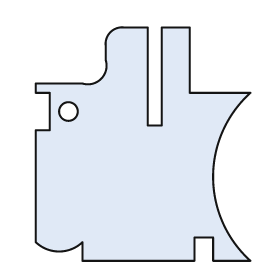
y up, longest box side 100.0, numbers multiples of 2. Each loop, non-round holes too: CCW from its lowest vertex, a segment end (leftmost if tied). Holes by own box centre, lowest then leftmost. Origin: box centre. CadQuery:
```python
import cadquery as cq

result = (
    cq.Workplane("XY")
    .moveTo(-26.0, -50.0)
    .lineTo(22.0, -50.0)
    .lineTo(22.0, -40.0)
    .lineTo(30.0, -40.0)
    .lineTo(30.0, -50.0)
    .lineTo(46.0, -50.0)
    .threePointArc((30.0, -14.0), (46.0, 22.0))
    .lineTo(20.0, 22.0)
    .lineTo(20.0, 50.0)
    .lineTo(8.0, 50.0)
    .lineTo(8.0, 8.0)
    .lineTo(2.0, 8.0)
    .lineTo(2.0, 50.0)
    .lineTo(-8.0, 50.0)
    .threePointArc((-14.0, 48.0), (-16.0, 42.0))
    .lineTo(-16.0, 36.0)
    .threePointArc((-18.0, 28.0), (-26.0, 26.0))
    .lineTo(-46.0, 26.0)
    .lineTo(-46.0, 22.0)
    .lineTo(-40.0, 22.0)
    .lineTo(-40.0, 6.0)
    .lineTo(-46.0, 6.0)
    .lineTo(-46.0, -42.0)
    .threePointArc((-36.0, -46.0), (-26.0, -42.0))
    .close()
    .moveTo(-32.0, 14.0)
    .circle(4.0)
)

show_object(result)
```